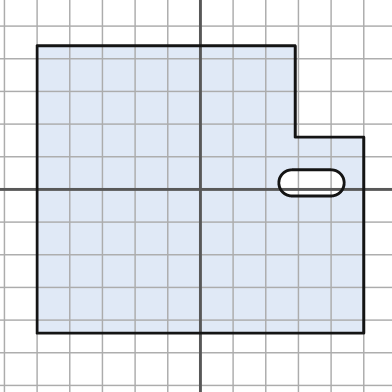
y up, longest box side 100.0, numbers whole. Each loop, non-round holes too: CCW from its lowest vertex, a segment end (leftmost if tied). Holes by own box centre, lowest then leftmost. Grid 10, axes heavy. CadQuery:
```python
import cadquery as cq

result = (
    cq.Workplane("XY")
    .moveTo(-50.0, -44.0)
    .lineTo(50.0, -44.0)
    .lineTo(50.0, 16.0)
    .lineTo(29.0, 16.0)
    .lineTo(29.0, 44.0)
    .lineTo(-50.0, 44.0)
    .close()
    .moveTo(28.0, -2.0)
    .lineTo(40.0, -2.0)
    .threePointArc((44.0, 2.0), (40.0, 6.0))
    .lineTo(28.0, 6.0)
    .threePointArc((24.0, 2.0), (28.0, -2.0))
    .close()
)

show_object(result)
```